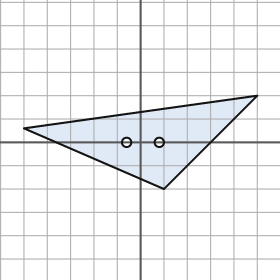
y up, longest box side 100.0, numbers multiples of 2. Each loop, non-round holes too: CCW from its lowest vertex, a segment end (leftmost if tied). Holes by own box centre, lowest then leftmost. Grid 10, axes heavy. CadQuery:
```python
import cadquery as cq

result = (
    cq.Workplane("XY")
    .moveTo(10.0, -20.0)
    .lineTo(50.0, 20.0)
    .lineTo(-50.0, 6.0)
    .close()
    .moveTo(-6.0, 0.0)
    .circle(2.0)
    .moveTo(8.0, 0.0)
    .circle(2.0)
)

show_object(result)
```